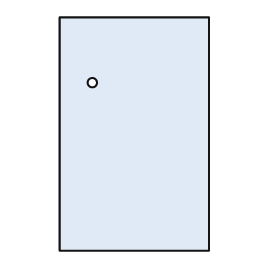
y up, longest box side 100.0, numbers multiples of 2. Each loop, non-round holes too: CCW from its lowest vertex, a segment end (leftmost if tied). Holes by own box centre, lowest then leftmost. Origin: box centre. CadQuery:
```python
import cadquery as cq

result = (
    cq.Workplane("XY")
    .moveTo(-32.0, -50.0)
    .lineTo(32.0, -50.0)
    .lineTo(32.0, 50.0)
    .lineTo(-32.0, 50.0)
    .close()
    .moveTo(-18.0, 22.0)
    .circle(2.0)
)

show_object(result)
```